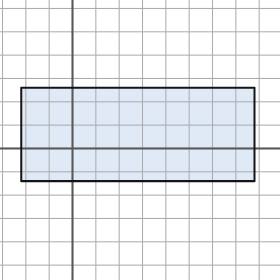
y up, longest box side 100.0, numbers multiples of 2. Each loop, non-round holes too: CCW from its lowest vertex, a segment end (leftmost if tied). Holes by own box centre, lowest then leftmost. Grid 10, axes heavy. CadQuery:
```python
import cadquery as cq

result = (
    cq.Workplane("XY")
    .moveTo(-22.0, -14.0)
    .lineTo(78.0, -14.0)
    .lineTo(78.0, 26.0)
    .lineTo(-22.0, 26.0)
    .close()
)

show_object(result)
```